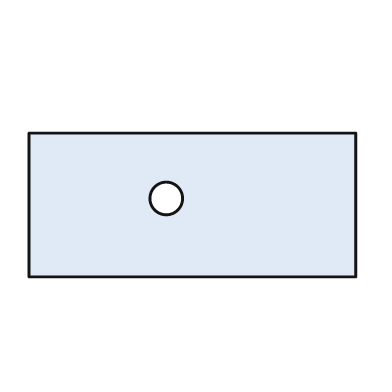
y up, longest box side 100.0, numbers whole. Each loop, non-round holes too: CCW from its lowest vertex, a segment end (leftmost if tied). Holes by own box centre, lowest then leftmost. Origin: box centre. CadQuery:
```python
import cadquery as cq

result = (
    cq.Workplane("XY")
    .moveTo(-50.0, -22.0)
    .lineTo(50.0, -22.0)
    .lineTo(50.0, 22.0)
    .lineTo(-50.0, 22.0)
    .close()
    .moveTo(-8.0, 2.0)
    .circle(5.0)
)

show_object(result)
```